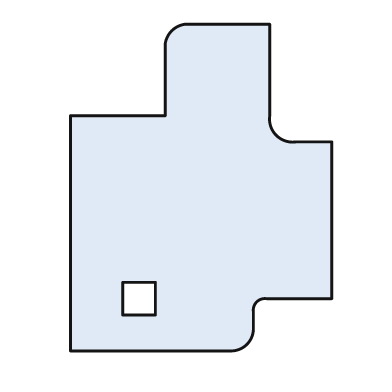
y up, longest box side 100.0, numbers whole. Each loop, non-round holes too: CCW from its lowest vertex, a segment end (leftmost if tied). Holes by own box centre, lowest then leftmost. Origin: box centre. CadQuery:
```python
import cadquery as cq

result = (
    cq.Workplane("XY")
    .moveTo(-40.0, -50.0)
    .lineTo(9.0, -50.0)
    .threePointArc((14.0, -48.0), (16.0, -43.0))
    .lineTo(16.0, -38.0)
    .threePointArc((17.0, -35.0), (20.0, -34.0))
    .lineTo(40.0, -34.0)
    .lineTo(40.0, 14.0)
    .lineTo(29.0, 14.0)
    .threePointArc((23.0, 16.0), (21.0, 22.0))
    .lineTo(21.0, 50.0)
    .lineTo(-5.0, 50.0)
    .threePointArc((-9.0, 48.0), (-11.0, 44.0))
    .lineTo(-11.0, 22.0)
    .lineTo(-40.0, 22.0)
    .close()
    .moveTo(-24.0, -39.0)
    .lineTo(-14.0, -39.0)
    .lineTo(-14.0, -29.0)
    .lineTo(-24.0, -29.0)
    .close()
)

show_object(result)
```